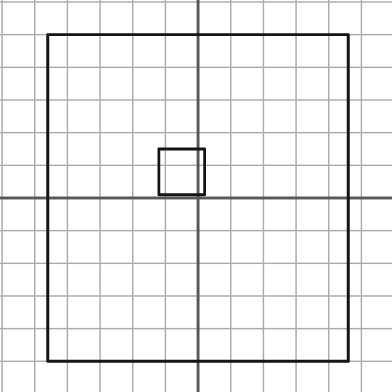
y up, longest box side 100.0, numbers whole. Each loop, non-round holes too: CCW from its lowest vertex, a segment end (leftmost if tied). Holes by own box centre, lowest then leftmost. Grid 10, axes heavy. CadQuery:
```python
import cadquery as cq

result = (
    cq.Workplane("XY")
    .moveTo(-46.0, -50.0)
    .lineTo(46.0, -50.0)
    .lineTo(46.0, 50.0)
    .lineTo(-46.0, 50.0)
    .close()
    .moveTo(-12.0, 1.0)
    .lineTo(2.0, 1.0)
    .lineTo(2.0, 15.0)
    .lineTo(-12.0, 15.0)
    .close()
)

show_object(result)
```